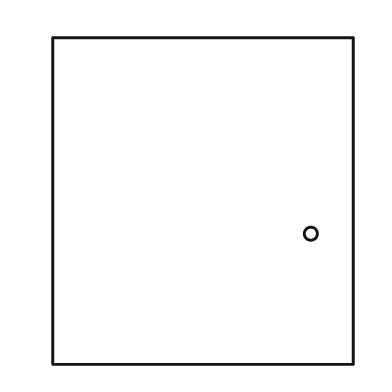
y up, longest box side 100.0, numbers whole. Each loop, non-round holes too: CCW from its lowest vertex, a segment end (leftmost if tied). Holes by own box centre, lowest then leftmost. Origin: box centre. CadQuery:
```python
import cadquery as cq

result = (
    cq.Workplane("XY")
    .moveTo(-46.0, -50.0)
    .lineTo(46.0, -50.0)
    .lineTo(46.0, 50.0)
    .lineTo(-46.0, 50.0)
    .close()
    .moveTo(33.0, -10.0)
    .circle(2.0)
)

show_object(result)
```